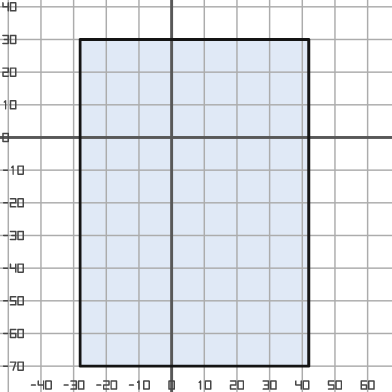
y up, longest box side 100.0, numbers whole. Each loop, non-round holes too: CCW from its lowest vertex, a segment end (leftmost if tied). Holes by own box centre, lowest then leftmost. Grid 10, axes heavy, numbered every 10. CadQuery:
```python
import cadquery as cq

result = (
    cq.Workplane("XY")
    .moveTo(-28.0, -70.0)
    .lineTo(42.0, -70.0)
    .lineTo(42.0, 30.0)
    .lineTo(-28.0, 30.0)
    .close()
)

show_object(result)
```